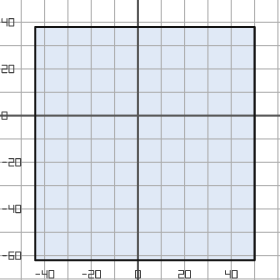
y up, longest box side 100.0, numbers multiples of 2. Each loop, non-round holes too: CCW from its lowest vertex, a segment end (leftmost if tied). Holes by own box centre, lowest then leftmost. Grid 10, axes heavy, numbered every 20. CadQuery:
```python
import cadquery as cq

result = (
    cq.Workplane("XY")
    .moveTo(-44.0, -62.0)
    .lineTo(50.0, -62.0)
    .lineTo(50.0, 38.0)
    .lineTo(-44.0, 38.0)
    .close()
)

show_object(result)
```